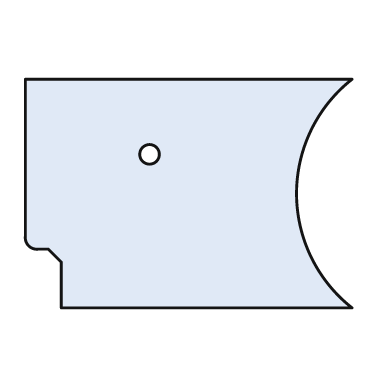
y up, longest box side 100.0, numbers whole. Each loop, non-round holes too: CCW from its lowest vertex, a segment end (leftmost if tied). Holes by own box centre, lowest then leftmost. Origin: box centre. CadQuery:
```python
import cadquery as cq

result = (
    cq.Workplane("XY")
    .moveTo(-39.0, -35.0)
    .lineTo(50.0, -35.0)
    .threePointArc((33.0, 0.0), (50.0, 35.0))
    .lineTo(-50.0, 35.0)
    .lineTo(-50.0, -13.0)
    .threePointArc((-49.0, -16.0), (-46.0, -17.0))
    .lineTo(-43.0, -17.0)
    .lineTo(-39.0, -21.0)
    .close()
    .moveTo(-12.0, 12.0)
    .circle(3.0)
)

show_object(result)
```